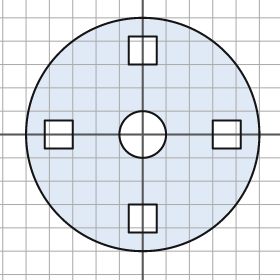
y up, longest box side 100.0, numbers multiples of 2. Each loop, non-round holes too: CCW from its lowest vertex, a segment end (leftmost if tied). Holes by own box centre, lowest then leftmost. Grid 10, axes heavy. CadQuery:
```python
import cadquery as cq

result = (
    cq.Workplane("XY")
    .moveTo(0.0, 0.0)
    .circle(50.0)
    .moveTo(-6.0, -42.0)
    .lineTo(6.0, -42.0)
    .lineTo(6.0, -30.0)
    .lineTo(-6.0, -30.0)
    .close()
    .moveTo(-42.0, -6.0)
    .lineTo(-30.0, -6.0)
    .lineTo(-30.0, 6.0)
    .lineTo(-42.0, 6.0)
    .close()
    .moveTo(0.0, 0.0)
    .circle(10.0)
    .moveTo(30.0, -6.0)
    .lineTo(42.0, -6.0)
    .lineTo(42.0, 6.0)
    .lineTo(30.0, 6.0)
    .close()
    .moveTo(-6.0, 30.0)
    .lineTo(6.0, 30.0)
    .lineTo(6.0, 42.0)
    .lineTo(-6.0, 42.0)
    .close()
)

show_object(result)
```